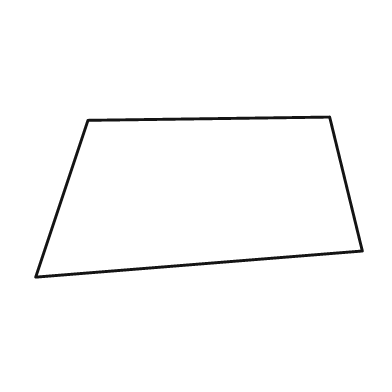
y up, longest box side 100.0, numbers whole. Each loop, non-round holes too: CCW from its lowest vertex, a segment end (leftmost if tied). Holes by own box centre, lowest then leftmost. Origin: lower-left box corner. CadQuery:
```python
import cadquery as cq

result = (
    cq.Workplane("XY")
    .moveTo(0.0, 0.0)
    .lineTo(100.0, 8.0)
    .lineTo(90.0, 49.0)
    .lineTo(16.0, 48.0)
    .close()
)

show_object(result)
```